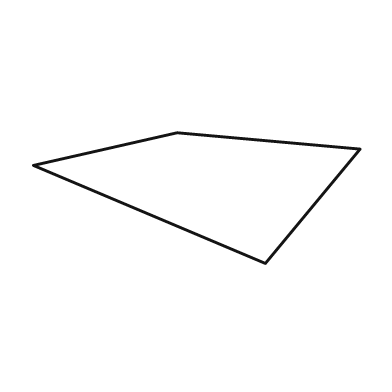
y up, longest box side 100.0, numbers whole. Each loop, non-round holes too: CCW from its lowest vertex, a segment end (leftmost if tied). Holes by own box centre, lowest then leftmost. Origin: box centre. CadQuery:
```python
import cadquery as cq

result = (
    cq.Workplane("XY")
    .moveTo(21.0, -20.0)
    .lineTo(50.0, 15.0)
    .lineTo(-6.0, 20.0)
    .lineTo(-50.0, 10.0)
    .close()
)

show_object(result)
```